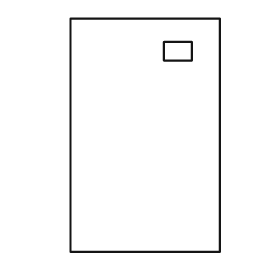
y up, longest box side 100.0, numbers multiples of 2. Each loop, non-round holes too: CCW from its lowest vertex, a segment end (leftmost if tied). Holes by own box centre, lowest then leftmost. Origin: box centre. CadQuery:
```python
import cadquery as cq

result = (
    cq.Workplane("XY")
    .moveTo(-32.0, -50.0)
    .lineTo(32.0, -50.0)
    .lineTo(32.0, 50.0)
    .lineTo(-32.0, 50.0)
    .close()
    .moveTo(8.0, 32.0)
    .lineTo(20.0, 32.0)
    .lineTo(20.0, 40.0)
    .lineTo(8.0, 40.0)
    .close()
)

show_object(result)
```